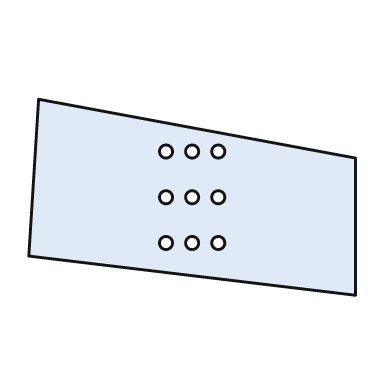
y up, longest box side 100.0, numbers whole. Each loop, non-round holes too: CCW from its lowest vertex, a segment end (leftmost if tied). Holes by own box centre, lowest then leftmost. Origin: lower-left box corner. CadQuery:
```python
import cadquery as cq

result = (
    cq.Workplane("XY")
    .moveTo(100.0, 0.0)
    .lineTo(100.0, 42.0)
    .lineTo(3.0, 60.0)
    .lineTo(0.0, 12.0)
    .close()
    .moveTo(42.0, 16.0)
    .circle(2.0)
    .moveTo(50.0, 16.0)
    .circle(2.0)
    .moveTo(58.0, 16.0)
    .circle(2.0)
    .moveTo(42.0, 30.0)
    .circle(2.0)
    .moveTo(50.0, 30.0)
    .circle(2.0)
    .moveTo(58.0, 30.0)
    .circle(2.0)
    .moveTo(42.0, 44.0)
    .circle(2.0)
    .moveTo(50.0, 44.0)
    .circle(2.0)
    .moveTo(58.0, 44.0)
    .circle(2.0)
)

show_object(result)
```